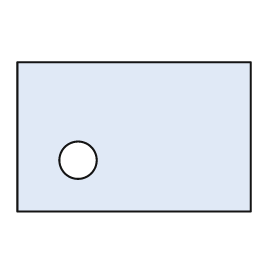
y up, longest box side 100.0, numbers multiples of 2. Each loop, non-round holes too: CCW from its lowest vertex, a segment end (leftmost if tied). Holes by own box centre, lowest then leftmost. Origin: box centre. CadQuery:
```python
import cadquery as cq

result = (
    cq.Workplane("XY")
    .moveTo(-50.0, -32.0)
    .lineTo(50.0, -32.0)
    .lineTo(50.0, 32.0)
    .lineTo(-50.0, 32.0)
    .close()
    .moveTo(-24.0, -10.0)
    .circle(8.0)
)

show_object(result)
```